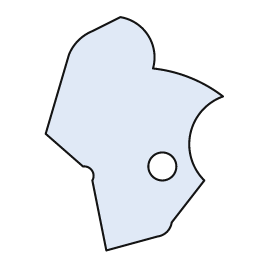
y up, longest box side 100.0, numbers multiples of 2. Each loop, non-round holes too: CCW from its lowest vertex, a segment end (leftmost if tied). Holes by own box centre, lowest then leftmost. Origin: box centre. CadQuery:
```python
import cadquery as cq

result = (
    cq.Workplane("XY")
    .moveTo(-12.0, -50.0)
    .lineTo(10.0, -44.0)
    .threePointArc((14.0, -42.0), (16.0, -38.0))
    .lineTo(30.0, -20.0)
    .threePointArc((24.0, 0.0), (38.0, 16.0))
    .threePointArc((24.0, 24.0), (8.0, 28.0))
    .threePointArc((6.0, 42.0), (-6.0, 50.0))
    .lineTo(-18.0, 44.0)
    .threePointArc((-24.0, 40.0), (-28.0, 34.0))
    .lineTo(-38.0, 0.0)
    .lineTo(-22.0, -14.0)
    .threePointArc((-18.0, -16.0), (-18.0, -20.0))
    .close()
    .moveTo(12.0, -14.0)
    .circle(6.0)
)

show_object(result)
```